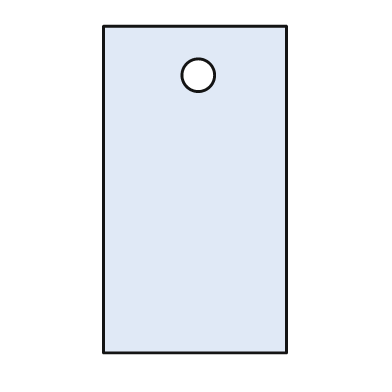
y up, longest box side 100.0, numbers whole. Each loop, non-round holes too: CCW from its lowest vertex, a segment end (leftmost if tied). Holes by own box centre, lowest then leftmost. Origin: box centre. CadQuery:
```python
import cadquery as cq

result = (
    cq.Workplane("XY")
    .moveTo(-28.0, -50.0)
    .lineTo(28.0, -50.0)
    .lineTo(28.0, 50.0)
    .lineTo(-28.0, 50.0)
    .close()
    .moveTo(1.0, 35.0)
    .circle(5.0)
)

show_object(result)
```